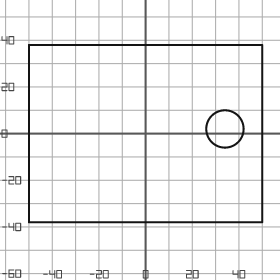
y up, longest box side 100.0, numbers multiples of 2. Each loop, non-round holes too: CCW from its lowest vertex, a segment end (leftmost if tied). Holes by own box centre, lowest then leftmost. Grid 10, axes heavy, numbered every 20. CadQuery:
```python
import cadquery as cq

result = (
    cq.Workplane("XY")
    .moveTo(-50.0, -38.0)
    .lineTo(50.0, -38.0)
    .lineTo(50.0, 38.0)
    .lineTo(-50.0, 38.0)
    .close()
    .moveTo(34.0, 2.0)
    .circle(8.0)
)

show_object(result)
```